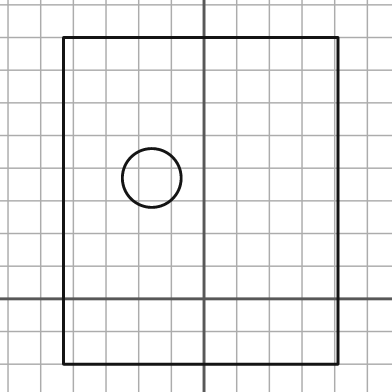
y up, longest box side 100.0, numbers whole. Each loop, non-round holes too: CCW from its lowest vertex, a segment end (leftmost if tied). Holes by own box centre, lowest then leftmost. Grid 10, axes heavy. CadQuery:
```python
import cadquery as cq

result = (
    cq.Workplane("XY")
    .moveTo(-43.0, -20.0)
    .lineTo(41.0, -20.0)
    .lineTo(41.0, 80.0)
    .lineTo(-43.0, 80.0)
    .close()
    .moveTo(-16.0, 37.0)
    .circle(9.0)
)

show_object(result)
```